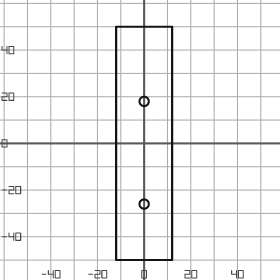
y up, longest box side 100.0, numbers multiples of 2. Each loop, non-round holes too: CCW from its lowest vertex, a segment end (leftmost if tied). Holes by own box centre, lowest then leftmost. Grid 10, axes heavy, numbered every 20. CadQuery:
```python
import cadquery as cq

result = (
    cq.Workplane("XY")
    .moveTo(-12.0, -50.0)
    .lineTo(12.0, -50.0)
    .lineTo(12.0, 50.0)
    .lineTo(-12.0, 50.0)
    .close()
    .moveTo(0.0, -26.0)
    .circle(2.0)
    .moveTo(0.0, 18.0)
    .circle(2.0)
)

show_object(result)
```